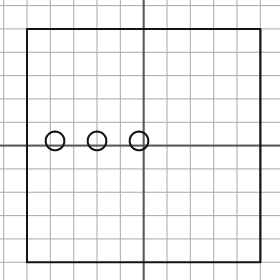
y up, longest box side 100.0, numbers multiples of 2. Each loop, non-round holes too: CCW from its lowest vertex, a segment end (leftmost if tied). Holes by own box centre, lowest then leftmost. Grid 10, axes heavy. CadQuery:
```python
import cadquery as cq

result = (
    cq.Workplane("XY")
    .moveTo(-50.0, -50.0)
    .lineTo(50.0, -50.0)
    .lineTo(50.0, 50.0)
    .lineTo(-50.0, 50.0)
    .close()
    .moveTo(-38.0, 2.0)
    .circle(4.0)
    .moveTo(-20.0, 2.0)
    .circle(4.0)
    .moveTo(-2.0, 2.0)
    .circle(4.0)
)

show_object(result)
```